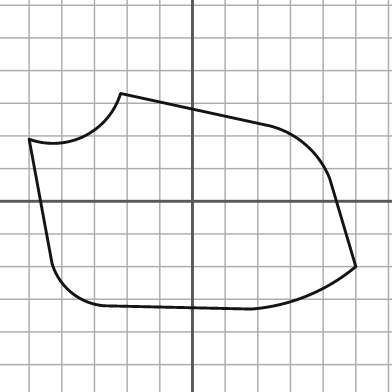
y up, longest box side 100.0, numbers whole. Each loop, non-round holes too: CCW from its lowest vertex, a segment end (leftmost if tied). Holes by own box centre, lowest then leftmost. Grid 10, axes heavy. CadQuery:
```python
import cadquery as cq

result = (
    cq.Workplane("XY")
    .moveTo(18.0, -33.0)
    .threePointArc((35.0, -29.0), (50.0, -20.0))
    .lineTo(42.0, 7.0)
    .threePointArc((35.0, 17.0), (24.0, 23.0))
    .lineTo(-22.0, 33.0)
    .threePointArc((-33.0, 20.0), (-50.0, 19.0))
    .lineTo(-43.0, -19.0)
    .threePointArc((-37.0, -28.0), (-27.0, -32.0))
    .close()
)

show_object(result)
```